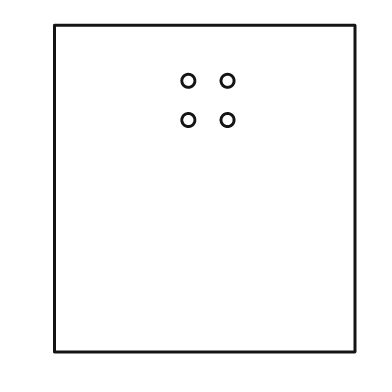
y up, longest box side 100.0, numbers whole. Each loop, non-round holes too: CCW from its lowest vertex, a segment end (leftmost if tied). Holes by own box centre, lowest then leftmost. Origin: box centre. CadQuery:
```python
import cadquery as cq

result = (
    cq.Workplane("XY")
    .moveTo(-46.0, -50.0)
    .lineTo(46.0, -50.0)
    .lineTo(46.0, 50.0)
    .lineTo(-46.0, 50.0)
    .close()
    .moveTo(-5.0, 21.0)
    .circle(2.0)
    .moveTo(7.0, 21.0)
    .circle(2.0)
    .moveTo(-5.0, 33.0)
    .circle(2.0)
    .moveTo(7.0, 33.0)
    .circle(2.0)
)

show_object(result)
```